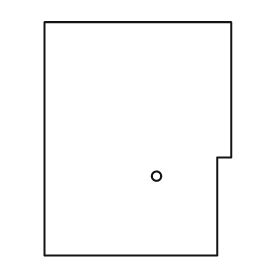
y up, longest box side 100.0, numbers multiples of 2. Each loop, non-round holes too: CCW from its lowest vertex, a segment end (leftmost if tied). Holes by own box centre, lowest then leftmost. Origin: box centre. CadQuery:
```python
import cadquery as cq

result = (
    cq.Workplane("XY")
    .moveTo(-40.0, -50.0)
    .lineTo(34.0, -50.0)
    .lineTo(34.0, -8.0)
    .lineTo(40.0, -8.0)
    .lineTo(40.0, 50.0)
    .lineTo(-40.0, 50.0)
    .close()
    .moveTo(8.0, -16.0)
    .circle(2.0)
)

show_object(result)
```